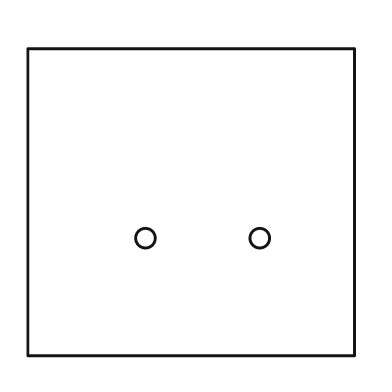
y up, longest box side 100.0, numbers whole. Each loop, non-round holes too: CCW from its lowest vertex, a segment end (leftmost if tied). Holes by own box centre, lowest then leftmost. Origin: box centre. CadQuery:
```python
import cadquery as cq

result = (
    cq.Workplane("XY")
    .moveTo(-50.0, -47.0)
    .lineTo(50.0, -47.0)
    .lineTo(50.0, 47.0)
    .lineTo(-50.0, 47.0)
    .close()
    .moveTo(-14.0, -11.0)
    .circle(3.0)
    .moveTo(21.0, -11.0)
    .circle(3.0)
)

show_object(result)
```